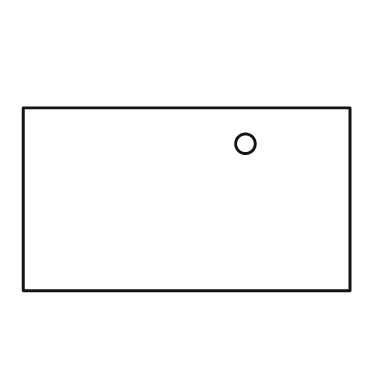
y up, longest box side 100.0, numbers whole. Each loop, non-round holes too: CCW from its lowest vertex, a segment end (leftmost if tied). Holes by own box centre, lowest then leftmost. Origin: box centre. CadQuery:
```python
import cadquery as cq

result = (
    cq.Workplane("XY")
    .moveTo(-50.0, -28.0)
    .lineTo(50.0, -28.0)
    .lineTo(50.0, 28.0)
    .lineTo(-50.0, 28.0)
    .close()
    .moveTo(18.0, 17.0)
    .circle(3.0)
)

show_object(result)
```